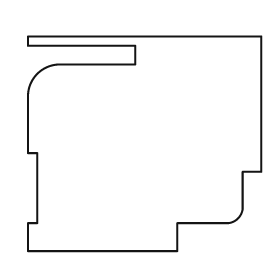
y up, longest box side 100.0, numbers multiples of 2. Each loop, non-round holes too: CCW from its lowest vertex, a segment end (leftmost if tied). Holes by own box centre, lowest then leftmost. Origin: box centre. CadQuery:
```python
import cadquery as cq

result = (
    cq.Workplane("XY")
    .moveTo(-50.0, -46.0)
    .lineTo(14.0, -46.0)
    .lineTo(14.0, -34.0)
    .lineTo(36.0, -34.0)
    .threePointArc((40.0, -32.0), (42.0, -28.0))
    .lineTo(42.0, -12.0)
    .lineTo(50.0, -12.0)
    .lineTo(50.0, 46.0)
    .lineTo(-50.0, 46.0)
    .lineTo(-50.0, 42.0)
    .lineTo(-4.0, 42.0)
    .lineTo(-4.0, 34.0)
    .lineTo(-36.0, 34.0)
    .threePointArc((-46.0, 30.0), (-50.0, 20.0))
    .lineTo(-50.0, -4.0)
    .lineTo(-46.0, -4.0)
    .lineTo(-46.0, -34.0)
    .lineTo(-50.0, -34.0)
    .close()
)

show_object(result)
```